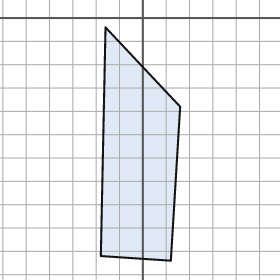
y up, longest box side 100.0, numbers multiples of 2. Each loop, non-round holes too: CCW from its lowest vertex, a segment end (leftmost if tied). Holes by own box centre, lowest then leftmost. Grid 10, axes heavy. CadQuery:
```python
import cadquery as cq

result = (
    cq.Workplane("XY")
    .moveTo(12.0, -104.0)
    .lineTo(16.0, -38.0)
    .lineTo(-16.0, -4.0)
    .lineTo(-18.0, -102.0)
    .close()
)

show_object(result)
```